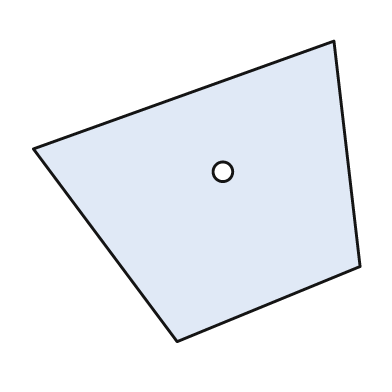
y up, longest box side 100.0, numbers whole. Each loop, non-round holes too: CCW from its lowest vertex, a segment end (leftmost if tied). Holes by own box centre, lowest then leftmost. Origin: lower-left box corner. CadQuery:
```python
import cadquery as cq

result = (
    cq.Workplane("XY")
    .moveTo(44.0, 0.0)
    .lineTo(100.0, 23.0)
    .lineTo(92.0, 92.0)
    .lineTo(0.0, 59.0)
    .close()
    .moveTo(58.0, 52.0)
    .circle(3.0)
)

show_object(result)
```